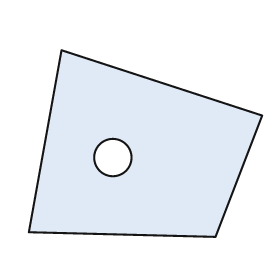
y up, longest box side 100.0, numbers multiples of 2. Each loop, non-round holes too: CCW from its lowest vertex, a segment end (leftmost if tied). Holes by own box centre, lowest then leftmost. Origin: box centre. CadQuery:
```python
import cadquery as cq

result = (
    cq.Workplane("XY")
    .moveTo(30.0, -40.0)
    .lineTo(50.0, 12.0)
    .lineTo(-36.0, 40.0)
    .lineTo(-50.0, -38.0)
    .close()
    .moveTo(-14.0, -6.0)
    .circle(8.0)
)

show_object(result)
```